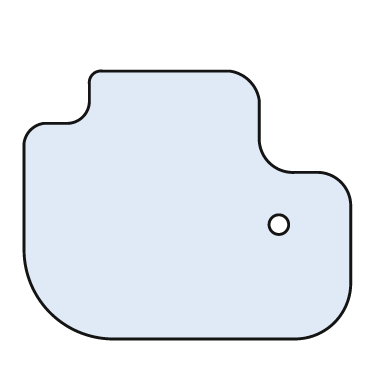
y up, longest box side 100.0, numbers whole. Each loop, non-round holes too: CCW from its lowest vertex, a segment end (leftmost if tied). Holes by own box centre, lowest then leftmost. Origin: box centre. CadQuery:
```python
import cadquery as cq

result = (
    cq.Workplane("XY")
    .moveTo(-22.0, -41.0)
    .lineTo(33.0, -41.0)
    .threePointArc((45.0, -36.0), (50.0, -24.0))
    .lineTo(50.0, 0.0)
    .threePointArc((47.0, 7.0), (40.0, 10.0))
    .lineTo(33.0, 10.0)
    .threePointArc((25.0, 13.0), (22.0, 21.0))
    .lineTo(22.0, 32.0)
    .threePointArc((19.0, 38.0), (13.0, 41.0))
    .lineTo(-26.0, 41.0)
    .threePointArc((-29.0, 40.0), (-30.0, 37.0))
    .lineTo(-30.0, 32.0)
    .threePointArc((-32.0, 27.0), (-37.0, 25.0))
    .lineTo(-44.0, 25.0)
    .threePointArc((-48.0, 23.0), (-50.0, 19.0))
    .lineTo(-50.0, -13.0)
    .threePointArc((-42.0, -33.0), (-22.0, -41.0))
    .close()
    .moveTo(28.0, -6.0)
    .circle(3.0)
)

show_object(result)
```